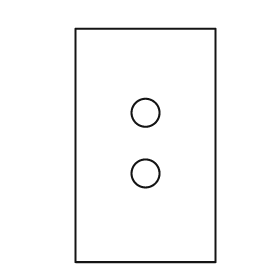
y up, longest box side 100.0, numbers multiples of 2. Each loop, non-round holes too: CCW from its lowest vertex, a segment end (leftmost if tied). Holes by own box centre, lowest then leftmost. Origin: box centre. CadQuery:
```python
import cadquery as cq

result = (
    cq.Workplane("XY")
    .moveTo(-30.0, -50.0)
    .lineTo(30.0, -50.0)
    .lineTo(30.0, 50.0)
    .lineTo(-30.0, 50.0)
    .close()
    .moveTo(0.0, -12.0)
    .circle(6.0)
    .moveTo(0.0, 14.0)
    .circle(6.0)
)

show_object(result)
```